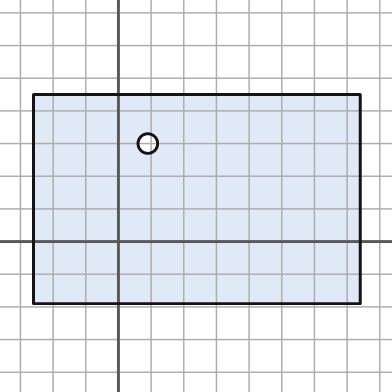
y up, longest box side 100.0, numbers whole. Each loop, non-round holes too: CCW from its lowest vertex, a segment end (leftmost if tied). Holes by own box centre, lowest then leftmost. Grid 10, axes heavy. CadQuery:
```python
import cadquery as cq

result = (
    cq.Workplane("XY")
    .moveTo(-26.0, -19.0)
    .lineTo(74.0, -19.0)
    .lineTo(74.0, 45.0)
    .lineTo(-26.0, 45.0)
    .close()
    .moveTo(9.0, 30.0)
    .circle(3.0)
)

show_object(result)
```